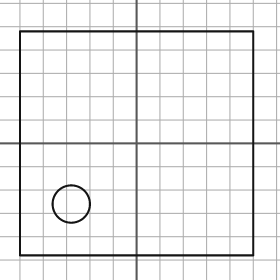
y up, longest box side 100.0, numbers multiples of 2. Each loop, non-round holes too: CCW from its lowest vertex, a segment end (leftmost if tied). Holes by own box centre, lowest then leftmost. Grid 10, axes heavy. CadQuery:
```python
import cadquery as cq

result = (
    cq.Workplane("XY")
    .moveTo(-50.0, -48.0)
    .lineTo(50.0, -48.0)
    .lineTo(50.0, 48.0)
    .lineTo(-50.0, 48.0)
    .close()
    .moveTo(-28.0, -26.0)
    .circle(8.0)
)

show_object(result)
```